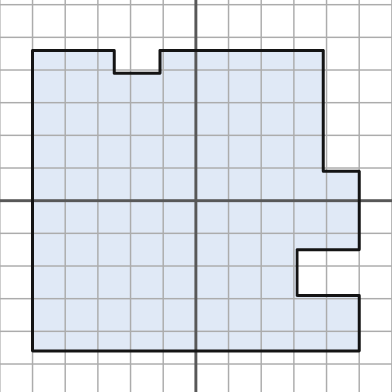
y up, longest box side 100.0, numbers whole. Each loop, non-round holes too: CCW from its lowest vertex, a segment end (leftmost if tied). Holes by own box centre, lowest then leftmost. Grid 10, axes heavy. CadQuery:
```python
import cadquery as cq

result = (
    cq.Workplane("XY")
    .moveTo(-50.0, -46.0)
    .lineTo(50.0, -46.0)
    .lineTo(50.0, -29.0)
    .lineTo(31.0, -29.0)
    .lineTo(31.0, -15.0)
    .lineTo(50.0, -15.0)
    .lineTo(50.0, 9.0)
    .lineTo(39.0, 9.0)
    .lineTo(39.0, 46.0)
    .lineTo(-11.0, 46.0)
    .lineTo(-11.0, 39.0)
    .lineTo(-25.0, 39.0)
    .lineTo(-25.0, 46.0)
    .lineTo(-50.0, 46.0)
    .close()
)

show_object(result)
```